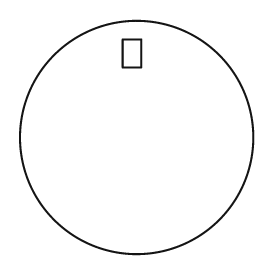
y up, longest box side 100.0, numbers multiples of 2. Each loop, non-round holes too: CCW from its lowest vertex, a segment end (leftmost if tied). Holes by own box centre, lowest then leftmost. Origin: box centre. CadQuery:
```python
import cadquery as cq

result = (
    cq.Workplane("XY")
    .moveTo(0.0, 0.0)
    .circle(50.0)
    .moveTo(-6.0, 30.0)
    .lineTo(2.0, 30.0)
    .lineTo(2.0, 42.0)
    .lineTo(-6.0, 42.0)
    .close()
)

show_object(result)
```